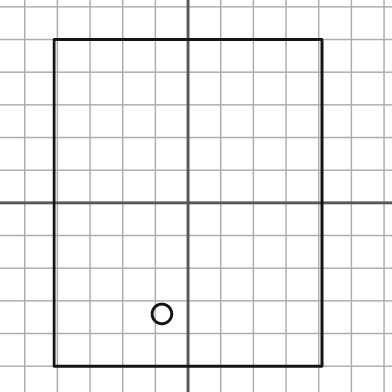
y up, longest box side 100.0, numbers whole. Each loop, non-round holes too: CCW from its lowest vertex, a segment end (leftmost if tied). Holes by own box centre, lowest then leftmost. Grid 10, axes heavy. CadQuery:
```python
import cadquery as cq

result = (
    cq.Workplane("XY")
    .moveTo(-41.0, -50.0)
    .lineTo(41.0, -50.0)
    .lineTo(41.0, 50.0)
    .lineTo(-41.0, 50.0)
    .close()
    .moveTo(-8.0, -34.0)
    .circle(3.0)
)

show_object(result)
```